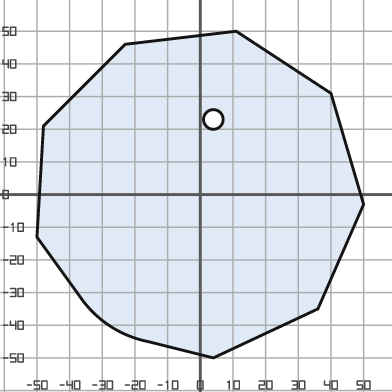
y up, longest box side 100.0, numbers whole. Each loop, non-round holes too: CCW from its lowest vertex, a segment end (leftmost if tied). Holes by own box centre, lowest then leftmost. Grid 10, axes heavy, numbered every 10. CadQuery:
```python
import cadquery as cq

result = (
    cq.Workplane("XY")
    .moveTo(4.0, -50.0)
    .lineTo(36.0, -35.0)
    .lineTo(50.0, -3.0)
    .lineTo(40.0, 31.0)
    .lineTo(11.0, 50.0)
    .lineTo(-23.0, 46.0)
    .lineTo(-48.0, 21.0)
    .lineTo(-50.0, -13.0)
    .lineTo(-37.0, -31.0)
    .threePointArc((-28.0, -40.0), (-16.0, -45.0))
    .close()
    .moveTo(4.0, 23.0)
    .circle(3.0)
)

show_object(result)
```